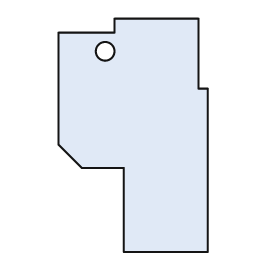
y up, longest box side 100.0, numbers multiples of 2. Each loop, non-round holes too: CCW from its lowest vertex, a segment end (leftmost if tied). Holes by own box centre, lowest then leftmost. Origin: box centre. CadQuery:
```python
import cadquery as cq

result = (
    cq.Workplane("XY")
    .moveTo(-4.0, -50.0)
    .lineTo(32.0, -50.0)
    .lineTo(32.0, 20.0)
    .lineTo(28.0, 20.0)
    .lineTo(28.0, 50.0)
    .lineTo(-8.0, 50.0)
    .lineTo(-8.0, 44.0)
    .lineTo(-32.0, 44.0)
    .lineTo(-32.0, -4.0)
    .lineTo(-22.0, -14.0)
    .lineTo(-4.0, -14.0)
    .close()
    .moveTo(-12.0, 36.0)
    .circle(4.0)
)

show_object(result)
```